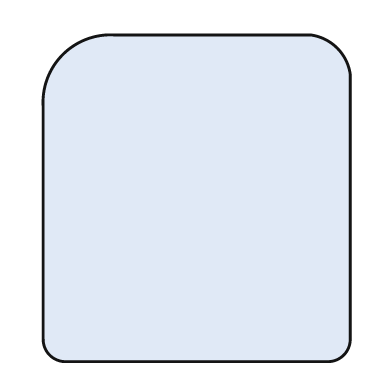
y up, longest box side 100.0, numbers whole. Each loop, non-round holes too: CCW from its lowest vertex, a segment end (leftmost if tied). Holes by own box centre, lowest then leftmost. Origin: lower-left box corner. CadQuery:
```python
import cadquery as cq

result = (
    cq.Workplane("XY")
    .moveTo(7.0, 0.0)
    .lineTo(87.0, 0.0)
    .threePointArc((92.0, 2.0), (94.0, 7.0))
    .lineTo(94.0, 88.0)
    .threePointArc((90.0, 96.0), (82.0, 100.0))
    .lineTo(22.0, 100.0)
    .threePointArc((6.0, 94.0), (0.0, 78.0))
    .lineTo(0.0, 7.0)
    .threePointArc((2.0, 2.0), (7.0, 0.0))
    .close()
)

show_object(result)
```